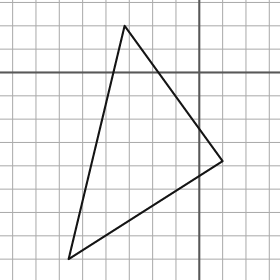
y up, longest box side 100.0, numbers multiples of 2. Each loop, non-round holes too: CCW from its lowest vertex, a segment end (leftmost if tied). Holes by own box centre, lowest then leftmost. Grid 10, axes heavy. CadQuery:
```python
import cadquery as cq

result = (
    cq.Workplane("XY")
    .moveTo(-56.0, -80.0)
    .lineTo(10.0, -38.0)
    .lineTo(-32.0, 20.0)
    .close()
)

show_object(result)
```